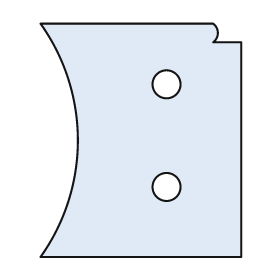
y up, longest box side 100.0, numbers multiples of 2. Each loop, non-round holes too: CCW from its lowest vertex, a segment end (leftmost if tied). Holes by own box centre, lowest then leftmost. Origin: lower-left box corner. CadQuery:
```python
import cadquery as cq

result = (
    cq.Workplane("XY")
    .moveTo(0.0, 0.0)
    .lineTo(86.0, 0.0)
    .lineTo(86.0, 92.0)
    .lineTo(74.0, 92.0)
    .threePointArc((76.0, 96.0), (74.0, 100.0))
    .lineTo(0.0, 100.0)
    .threePointArc((16.0, 50.0), (0.0, 0.0))
    .close()
    .moveTo(54.0, 30.0)
    .circle(6.0)
    .moveTo(54.0, 74.0)
    .circle(6.0)
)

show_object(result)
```